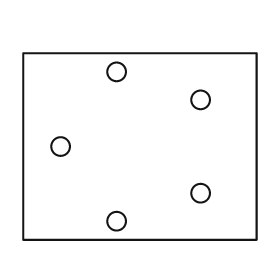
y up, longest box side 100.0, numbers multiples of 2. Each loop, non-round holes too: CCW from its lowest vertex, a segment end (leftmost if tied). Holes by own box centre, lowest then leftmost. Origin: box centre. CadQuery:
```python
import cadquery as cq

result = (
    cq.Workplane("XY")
    .moveTo(-50.0, -40.0)
    .lineTo(50.0, -40.0)
    .lineTo(50.0, 40.0)
    .lineTo(-50.0, 40.0)
    .close()
    .moveTo(-10.0, -32.0)
    .circle(4.0)
    .moveTo(26.0, -20.0)
    .circle(4.0)
    .moveTo(-34.0, 0.0)
    .circle(4.0)
    .moveTo(26.0, 20.0)
    .circle(4.0)
    .moveTo(-10.0, 32.0)
    .circle(4.0)
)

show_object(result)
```